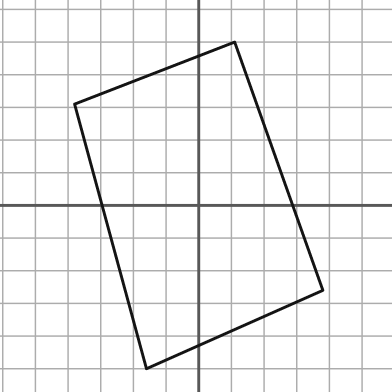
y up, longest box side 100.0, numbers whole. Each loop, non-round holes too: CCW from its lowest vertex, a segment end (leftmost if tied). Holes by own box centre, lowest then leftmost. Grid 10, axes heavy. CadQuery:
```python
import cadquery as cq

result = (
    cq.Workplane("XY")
    .moveTo(-16.0, -50.0)
    .lineTo(38.0, -26.0)
    .lineTo(11.0, 50.0)
    .lineTo(-38.0, 31.0)
    .close()
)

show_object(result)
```